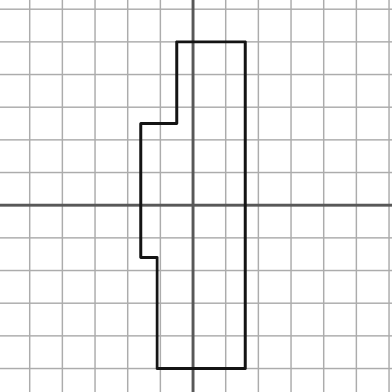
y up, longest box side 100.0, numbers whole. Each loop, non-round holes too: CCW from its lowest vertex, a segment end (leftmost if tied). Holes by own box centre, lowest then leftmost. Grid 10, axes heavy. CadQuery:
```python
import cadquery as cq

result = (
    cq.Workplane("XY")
    .moveTo(-11.0, -50.0)
    .lineTo(16.0, -50.0)
    .lineTo(16.0, 50.0)
    .lineTo(-5.0, 50.0)
    .lineTo(-5.0, 25.0)
    .lineTo(-16.0, 25.0)
    .lineTo(-16.0, -16.0)
    .lineTo(-11.0, -16.0)
    .close()
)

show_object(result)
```